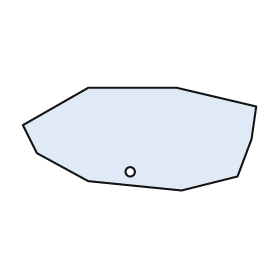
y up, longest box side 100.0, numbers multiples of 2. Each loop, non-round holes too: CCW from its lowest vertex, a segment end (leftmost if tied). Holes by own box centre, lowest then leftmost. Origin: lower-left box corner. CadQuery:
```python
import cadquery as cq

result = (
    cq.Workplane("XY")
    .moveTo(68.0, 0.0)
    .lineTo(92.0, 6.0)
    .lineTo(98.0, 22.0)
    .lineTo(100.0, 36.0)
    .lineTo(66.0, 44.0)
    .lineTo(28.0, 44.0)
    .lineTo(0.0, 28.0)
    .lineTo(6.0, 16.0)
    .lineTo(28.0, 4.0)
    .close()
    .moveTo(46.0, 8.0)
    .circle(2.0)
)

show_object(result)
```